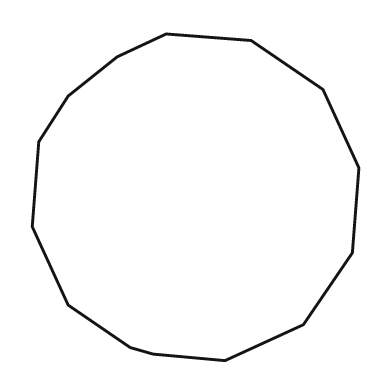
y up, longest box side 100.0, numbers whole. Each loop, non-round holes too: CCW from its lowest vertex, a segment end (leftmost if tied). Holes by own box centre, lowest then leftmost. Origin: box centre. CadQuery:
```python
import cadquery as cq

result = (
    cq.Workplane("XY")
    .moveTo(9.0, -50.0)
    .lineTo(33.0, -39.0)
    .lineTo(48.0, -17.0)
    .lineTo(50.0, 9.0)
    .lineTo(39.0, 33.0)
    .lineTo(17.0, 48.0)
    .lineTo(-9.0, 50.0)
    .lineTo(-24.0, 43.0)
    .lineTo(-39.0, 31.0)
    .lineTo(-48.0, 17.0)
    .lineTo(-50.0, -9.0)
    .lineTo(-39.0, -33.0)
    .lineTo(-20.0, -46.0)
    .lineTo(-13.0, -48.0)
    .close()
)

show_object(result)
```